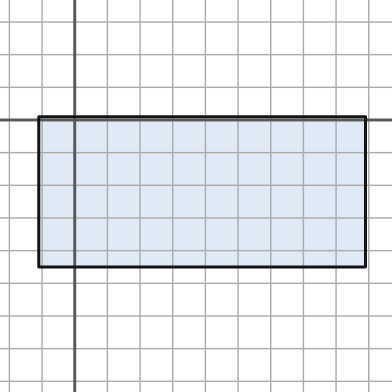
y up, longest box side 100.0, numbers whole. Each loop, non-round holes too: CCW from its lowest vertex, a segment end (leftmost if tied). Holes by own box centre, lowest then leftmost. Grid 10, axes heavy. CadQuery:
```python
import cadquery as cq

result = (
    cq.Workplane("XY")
    .moveTo(-11.0, -45.0)
    .lineTo(89.0, -45.0)
    .lineTo(89.0, 1.0)
    .lineTo(-11.0, 1.0)
    .close()
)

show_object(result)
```